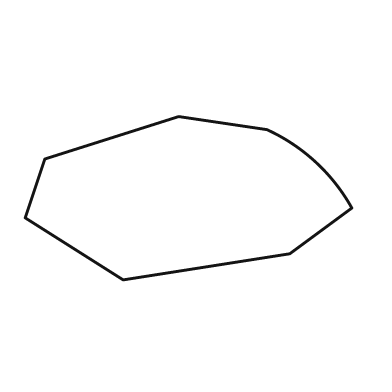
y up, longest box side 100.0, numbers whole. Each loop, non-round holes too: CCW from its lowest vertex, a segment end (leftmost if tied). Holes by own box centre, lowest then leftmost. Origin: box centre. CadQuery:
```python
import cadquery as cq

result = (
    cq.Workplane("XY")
    .moveTo(-20.0, -25.0)
    .lineTo(31.0, -17.0)
    .lineTo(50.0, -3.0)
    .threePointArc((39.0, 11.0), (24.0, 21.0))
    .lineTo(-3.0, 25.0)
    .lineTo(-44.0, 12.0)
    .lineTo(-50.0, -6.0)
    .close()
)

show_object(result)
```